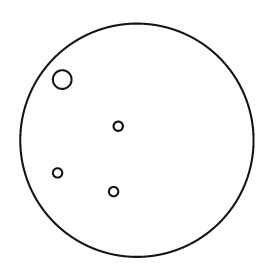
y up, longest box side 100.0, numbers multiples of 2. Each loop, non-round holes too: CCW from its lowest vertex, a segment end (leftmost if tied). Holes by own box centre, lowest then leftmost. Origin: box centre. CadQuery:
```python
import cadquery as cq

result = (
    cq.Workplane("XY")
    .moveTo(0.0, 0.0)
    .circle(50.0)
    .moveTo(-10.0, -22.0)
    .circle(2.0)
    .moveTo(-34.0, -14.0)
    .circle(2.0)
    .moveTo(-8.0, 6.0)
    .circle(2.0)
    .moveTo(-32.0, 26.0)
    .circle(4.0)
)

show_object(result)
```